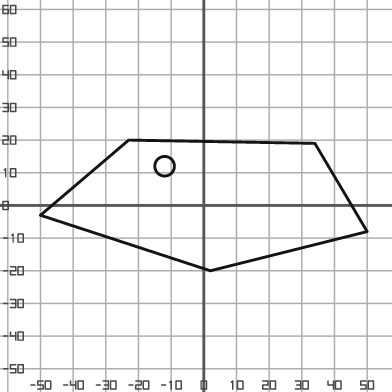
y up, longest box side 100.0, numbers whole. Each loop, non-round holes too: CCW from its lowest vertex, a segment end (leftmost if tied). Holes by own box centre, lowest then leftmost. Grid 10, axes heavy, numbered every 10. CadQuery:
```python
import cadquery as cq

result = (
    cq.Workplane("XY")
    .moveTo(2.0, -20.0)
    .lineTo(50.0, -8.0)
    .lineTo(34.0, 19.0)
    .lineTo(-23.0, 20.0)
    .lineTo(-50.0, -3.0)
    .close()
    .moveTo(-12.0, 12.0)
    .circle(3.0)
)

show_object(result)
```